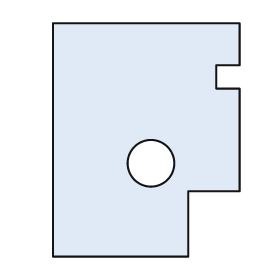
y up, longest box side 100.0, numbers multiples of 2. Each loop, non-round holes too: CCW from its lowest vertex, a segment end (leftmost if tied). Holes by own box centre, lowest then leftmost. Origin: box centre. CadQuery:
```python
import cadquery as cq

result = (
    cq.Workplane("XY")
    .moveTo(-40.0, -50.0)
    .lineTo(18.0, -50.0)
    .lineTo(18.0, -22.0)
    .lineTo(40.0, -22.0)
    .lineTo(40.0, 22.0)
    .lineTo(30.0, 22.0)
    .lineTo(30.0, 32.0)
    .lineTo(40.0, 32.0)
    .lineTo(40.0, 50.0)
    .lineTo(-40.0, 50.0)
    .close()
    .moveTo(2.0, -10.0)
    .circle(10.0)
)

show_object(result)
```